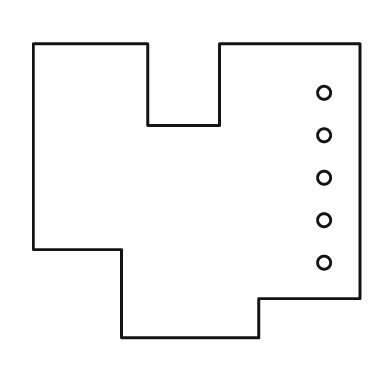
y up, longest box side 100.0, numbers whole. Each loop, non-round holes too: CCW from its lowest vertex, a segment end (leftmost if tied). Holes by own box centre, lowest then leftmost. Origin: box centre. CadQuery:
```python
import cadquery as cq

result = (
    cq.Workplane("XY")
    .moveTo(-23.0, -45.0)
    .lineTo(19.0, -45.0)
    .lineTo(19.0, -33.0)
    .lineTo(50.0, -33.0)
    .lineTo(50.0, 45.0)
    .lineTo(7.0, 45.0)
    .lineTo(7.0, 20.0)
    .lineTo(-15.0, 20.0)
    .lineTo(-15.0, 45.0)
    .lineTo(-50.0, 45.0)
    .lineTo(-50.0, -18.0)
    .lineTo(-23.0, -18.0)
    .close()
    .moveTo(39.0, -22.0)
    .circle(2.0)
    .moveTo(39.0, -9.0)
    .circle(2.0)
    .moveTo(39.0, 4.0)
    .circle(2.0)
    .moveTo(39.0, 17.0)
    .circle(2.0)
    .moveTo(39.0, 30.0)
    .circle(2.0)
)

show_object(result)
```